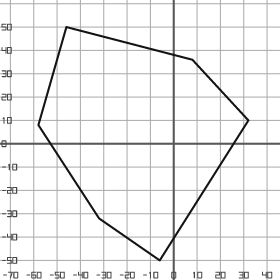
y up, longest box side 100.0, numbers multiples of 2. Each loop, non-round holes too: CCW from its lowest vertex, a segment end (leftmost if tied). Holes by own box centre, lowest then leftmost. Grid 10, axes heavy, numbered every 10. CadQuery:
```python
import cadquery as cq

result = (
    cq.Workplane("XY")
    .moveTo(-6.0, -50.0)
    .lineTo(32.0, 10.0)
    .lineTo(8.0, 36.0)
    .lineTo(-46.0, 50.0)
    .lineTo(-58.0, 8.0)
    .lineTo(-32.0, -32.0)
    .close()
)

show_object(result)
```